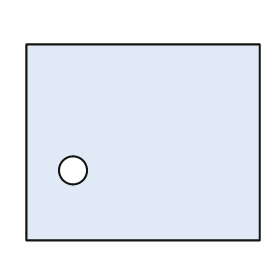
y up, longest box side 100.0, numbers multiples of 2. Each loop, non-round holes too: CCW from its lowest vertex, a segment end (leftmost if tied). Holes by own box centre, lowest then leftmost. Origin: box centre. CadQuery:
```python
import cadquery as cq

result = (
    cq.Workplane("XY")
    .moveTo(-50.0, -42.0)
    .lineTo(50.0, -42.0)
    .lineTo(50.0, 42.0)
    .lineTo(-50.0, 42.0)
    .close()
    .moveTo(-30.0, -12.0)
    .circle(6.0)
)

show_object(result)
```